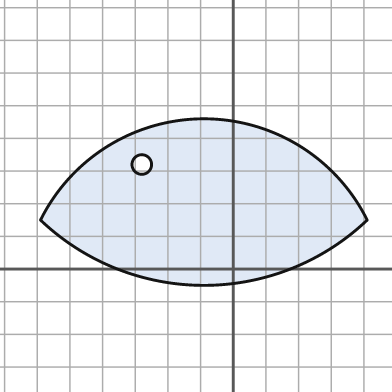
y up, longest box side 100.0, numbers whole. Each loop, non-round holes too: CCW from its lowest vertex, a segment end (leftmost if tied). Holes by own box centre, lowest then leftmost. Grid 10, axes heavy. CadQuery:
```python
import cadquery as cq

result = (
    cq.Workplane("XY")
    .moveTo(-59.0, 15.0)
    .threePointArc((-9.0, -5.0), (41.0, 15.0))
    .threePointArc((-9.0, 46.0), (-59.0, 15.0))
    .close()
    .moveTo(-28.0, 32.0)
    .circle(3.0)
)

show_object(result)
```